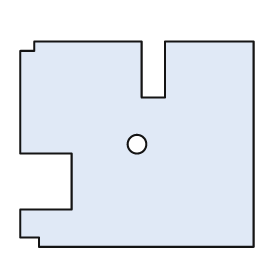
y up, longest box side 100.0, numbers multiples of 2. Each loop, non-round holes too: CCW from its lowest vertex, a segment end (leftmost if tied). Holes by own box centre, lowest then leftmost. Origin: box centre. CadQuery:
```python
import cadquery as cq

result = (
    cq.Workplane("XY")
    .moveTo(-42.0, -44.0)
    .lineTo(50.0, -44.0)
    .lineTo(50.0, 44.0)
    .lineTo(12.0, 44.0)
    .lineTo(12.0, 20.0)
    .lineTo(2.0, 20.0)
    .lineTo(2.0, 44.0)
    .lineTo(-44.0, 44.0)
    .lineTo(-44.0, 40.0)
    .lineTo(-50.0, 40.0)
    .lineTo(-50.0, -4.0)
    .lineTo(-28.0, -4.0)
    .lineTo(-28.0, -28.0)
    .lineTo(-50.0, -28.0)
    .lineTo(-50.0, -40.0)
    .lineTo(-42.0, -40.0)
    .close()
    .moveTo(0.0, 0.0)
    .circle(4.0)
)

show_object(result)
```